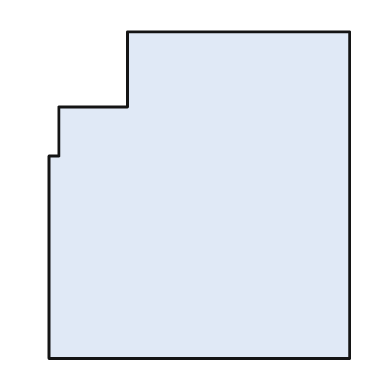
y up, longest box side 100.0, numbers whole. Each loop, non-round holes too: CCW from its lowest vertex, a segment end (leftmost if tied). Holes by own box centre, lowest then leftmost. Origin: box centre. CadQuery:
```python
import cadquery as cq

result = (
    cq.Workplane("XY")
    .moveTo(-46.0, -50.0)
    .lineTo(46.0, -50.0)
    .lineTo(46.0, 50.0)
    .lineTo(-22.0, 50.0)
    .lineTo(-22.0, 27.0)
    .lineTo(-43.0, 27.0)
    .lineTo(-43.0, 12.0)
    .lineTo(-46.0, 12.0)
    .close()
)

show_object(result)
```